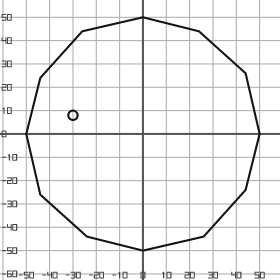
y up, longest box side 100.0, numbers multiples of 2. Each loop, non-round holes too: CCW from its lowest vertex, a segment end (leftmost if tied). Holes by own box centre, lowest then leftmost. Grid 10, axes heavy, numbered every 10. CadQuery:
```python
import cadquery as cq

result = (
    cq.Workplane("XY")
    .moveTo(0.0, -50.0)
    .lineTo(26.0, -44.0)
    .lineTo(44.0, -24.0)
    .lineTo(50.0, 0.0)
    .lineTo(44.0, 26.0)
    .lineTo(24.0, 44.0)
    .lineTo(0.0, 50.0)
    .lineTo(-26.0, 44.0)
    .lineTo(-44.0, 24.0)
    .lineTo(-50.0, 0.0)
    .lineTo(-44.0, -26.0)
    .lineTo(-24.0, -44.0)
    .close()
    .moveTo(-30.0, 8.0)
    .circle(2.0)
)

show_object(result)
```